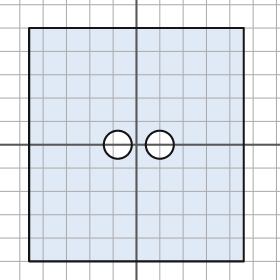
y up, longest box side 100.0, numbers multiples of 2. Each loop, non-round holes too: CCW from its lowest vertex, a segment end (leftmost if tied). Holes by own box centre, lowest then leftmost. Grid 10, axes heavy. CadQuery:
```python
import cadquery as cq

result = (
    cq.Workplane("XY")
    .moveTo(-46.0, -50.0)
    .lineTo(46.0, -50.0)
    .lineTo(46.0, 50.0)
    .lineTo(-46.0, 50.0)
    .close()
    .moveTo(-8.0, 0.0)
    .circle(6.0)
    .moveTo(10.0, 0.0)
    .circle(6.0)
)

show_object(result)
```